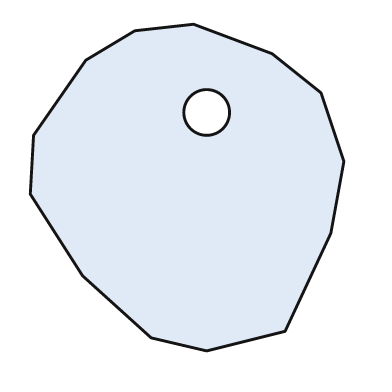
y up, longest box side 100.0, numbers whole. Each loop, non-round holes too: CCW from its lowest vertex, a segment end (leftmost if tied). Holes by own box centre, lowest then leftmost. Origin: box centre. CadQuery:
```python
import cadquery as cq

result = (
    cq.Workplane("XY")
    .moveTo(6.0, -50.0)
    .lineTo(30.0, -44.0)
    .lineTo(44.0, -14.0)
    .lineTo(48.0, 8.0)
    .lineTo(41.0, 29.0)
    .lineTo(26.0, 41.0)
    .lineTo(2.0, 50.0)
    .lineTo(-16.0, 48.0)
    .lineTo(-31.0, 39.0)
    .lineTo(-47.0, 16.0)
    .lineTo(-48.0, -2.0)
    .lineTo(-32.0, -27.0)
    .lineTo(-11.0, -46.0)
    .close()
    .moveTo(6.0, 23.0)
    .circle(7.0)
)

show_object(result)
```